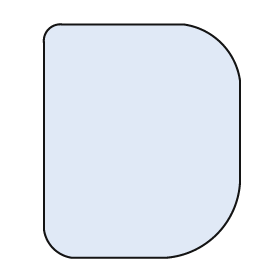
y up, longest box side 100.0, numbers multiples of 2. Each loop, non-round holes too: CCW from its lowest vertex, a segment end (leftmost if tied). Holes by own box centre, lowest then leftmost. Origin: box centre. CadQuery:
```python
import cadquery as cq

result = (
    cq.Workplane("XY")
    .moveTo(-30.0, -50.0)
    .lineTo(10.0, -50.0)
    .threePointArc((32.0, -40.0), (42.0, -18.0))
    .lineTo(42.0, 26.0)
    .threePointArc((34.0, 42.0), (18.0, 50.0))
    .lineTo(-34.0, 50.0)
    .threePointArc((-40.0, 48.0), (-42.0, 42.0))
    .lineTo(-42.0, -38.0)
    .threePointArc((-38.0, -46.0), (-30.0, -50.0))
    .close()
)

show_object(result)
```